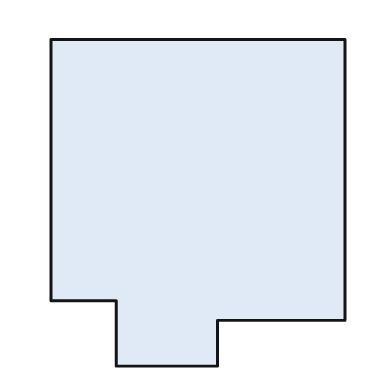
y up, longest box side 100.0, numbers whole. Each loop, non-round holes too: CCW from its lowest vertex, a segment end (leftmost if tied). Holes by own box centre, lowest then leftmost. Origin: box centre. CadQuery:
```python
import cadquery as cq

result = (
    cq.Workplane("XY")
    .moveTo(-25.0, -50.0)
    .lineTo(6.0, -50.0)
    .lineTo(6.0, -36.0)
    .lineTo(45.0, -36.0)
    .lineTo(45.0, 50.0)
    .lineTo(-45.0, 50.0)
    .lineTo(-45.0, -30.0)
    .lineTo(-25.0, -30.0)
    .close()
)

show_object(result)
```